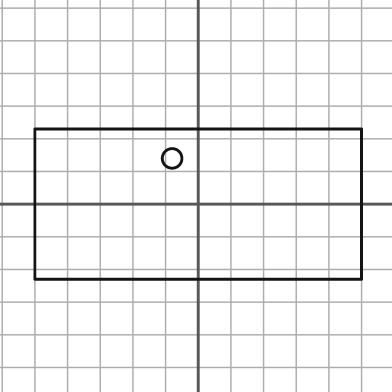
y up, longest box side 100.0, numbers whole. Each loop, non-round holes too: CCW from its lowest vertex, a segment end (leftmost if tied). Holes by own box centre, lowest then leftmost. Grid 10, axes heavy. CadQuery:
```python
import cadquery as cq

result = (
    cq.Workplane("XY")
    .moveTo(-50.0, -23.0)
    .lineTo(50.0, -23.0)
    .lineTo(50.0, 23.0)
    .lineTo(-50.0, 23.0)
    .close()
    .moveTo(-8.0, 14.0)
    .circle(3.0)
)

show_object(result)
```